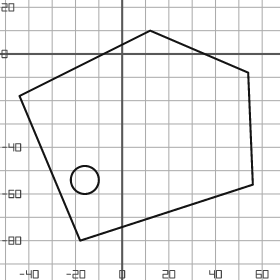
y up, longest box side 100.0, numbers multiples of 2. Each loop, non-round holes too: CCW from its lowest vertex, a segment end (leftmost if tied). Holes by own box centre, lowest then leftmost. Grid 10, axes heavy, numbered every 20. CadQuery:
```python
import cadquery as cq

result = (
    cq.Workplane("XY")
    .moveTo(-18.0, -80.0)
    .lineTo(56.0, -56.0)
    .lineTo(54.0, -8.0)
    .lineTo(12.0, 10.0)
    .lineTo(-44.0, -18.0)
    .close()
    .moveTo(-16.0, -54.0)
    .circle(6.0)
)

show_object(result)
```